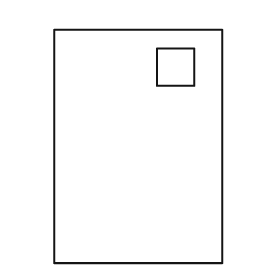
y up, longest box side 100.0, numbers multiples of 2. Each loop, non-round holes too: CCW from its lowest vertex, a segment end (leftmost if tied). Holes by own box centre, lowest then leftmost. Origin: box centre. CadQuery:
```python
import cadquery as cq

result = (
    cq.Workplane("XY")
    .moveTo(-36.0, -50.0)
    .lineTo(36.0, -50.0)
    .lineTo(36.0, 50.0)
    .lineTo(-36.0, 50.0)
    .close()
    .moveTo(8.0, 26.0)
    .lineTo(24.0, 26.0)
    .lineTo(24.0, 42.0)
    .lineTo(8.0, 42.0)
    .close()
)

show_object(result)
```